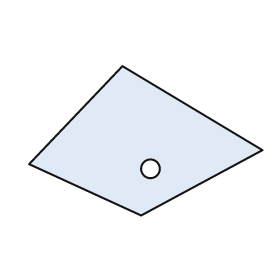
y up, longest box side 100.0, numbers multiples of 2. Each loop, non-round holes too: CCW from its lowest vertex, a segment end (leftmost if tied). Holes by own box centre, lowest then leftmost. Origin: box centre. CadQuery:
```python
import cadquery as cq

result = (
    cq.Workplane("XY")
    .moveTo(-2.0, -32.0)
    .lineTo(50.0, -4.0)
    .lineTo(-10.0, 32.0)
    .lineTo(-50.0, -10.0)
    .close()
    .moveTo(2.0, -12.0)
    .circle(4.0)
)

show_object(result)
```